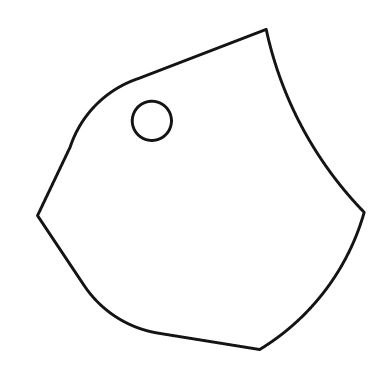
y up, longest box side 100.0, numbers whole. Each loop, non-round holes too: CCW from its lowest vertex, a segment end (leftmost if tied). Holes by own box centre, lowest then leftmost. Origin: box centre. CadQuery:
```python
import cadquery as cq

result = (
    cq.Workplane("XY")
    .moveTo(18.0, -49.0)
    .threePointArc((38.0, -31.0), (50.0, -7.0))
    .threePointArc((31.0, 19.0), (20.0, 49.0))
    .lineTo(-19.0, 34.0)
    .threePointArc((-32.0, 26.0), (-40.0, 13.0))
    .lineTo(-50.0, -8.0)
    .lineTo(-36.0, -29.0)
    .threePointArc((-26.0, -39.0), (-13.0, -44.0))
    .close()
    .moveTo(-15.0, 21.0)
    .circle(6.0)
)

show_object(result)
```